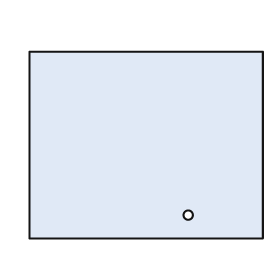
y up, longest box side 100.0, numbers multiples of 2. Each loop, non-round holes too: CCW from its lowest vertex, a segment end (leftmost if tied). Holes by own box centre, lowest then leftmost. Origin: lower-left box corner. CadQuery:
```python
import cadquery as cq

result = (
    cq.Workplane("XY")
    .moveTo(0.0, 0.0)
    .lineTo(100.0, 0.0)
    .lineTo(100.0, 80.0)
    .lineTo(0.0, 80.0)
    .close()
    .moveTo(68.0, 10.0)
    .circle(2.0)
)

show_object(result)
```